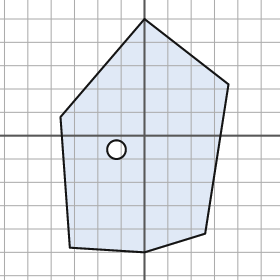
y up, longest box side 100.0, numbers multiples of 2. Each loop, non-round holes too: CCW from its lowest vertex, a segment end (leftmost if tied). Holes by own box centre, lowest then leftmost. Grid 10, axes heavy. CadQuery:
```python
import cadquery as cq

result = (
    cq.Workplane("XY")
    .moveTo(0.0, -50.0)
    .lineTo(26.0, -42.0)
    .lineTo(36.0, 22.0)
    .lineTo(0.0, 50.0)
    .lineTo(-36.0, 8.0)
    .lineTo(-32.0, -48.0)
    .close()
    .moveTo(-12.0, -6.0)
    .circle(4.0)
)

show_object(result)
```